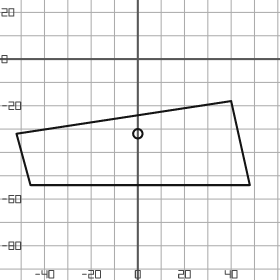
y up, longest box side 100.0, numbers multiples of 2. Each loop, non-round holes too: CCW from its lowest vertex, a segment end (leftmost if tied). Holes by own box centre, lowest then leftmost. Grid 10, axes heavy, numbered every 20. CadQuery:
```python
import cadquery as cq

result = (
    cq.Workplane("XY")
    .moveTo(-46.0, -54.0)
    .lineTo(48.0, -54.0)
    .lineTo(40.0, -18.0)
    .lineTo(-52.0, -32.0)
    .close()
    .moveTo(0.0, -32.0)
    .circle(2.0)
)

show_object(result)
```